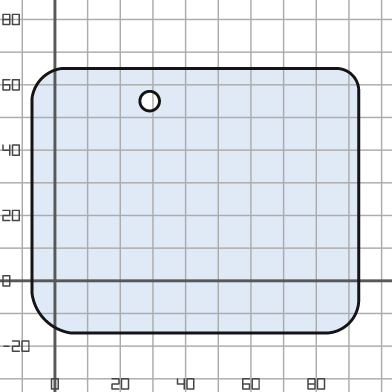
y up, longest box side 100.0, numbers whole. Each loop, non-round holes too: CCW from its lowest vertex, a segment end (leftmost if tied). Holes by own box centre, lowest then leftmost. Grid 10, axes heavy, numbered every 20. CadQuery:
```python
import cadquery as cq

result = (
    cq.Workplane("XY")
    .moveTo(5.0, -16.0)
    .lineTo(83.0, -16.0)
    .threePointArc((90.0, -13.0), (93.0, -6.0))
    .lineTo(93.0, 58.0)
    .threePointArc((91.0, 63.0), (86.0, 65.0))
    .lineTo(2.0, 65.0)
    .threePointArc((-4.0, 62.0), (-7.0, 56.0))
    .lineTo(-7.0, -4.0)
    .threePointArc((-3.0, -12.0), (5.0, -16.0))
    .close()
    .moveTo(29.0, 55.0)
    .circle(3.0)
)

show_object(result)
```